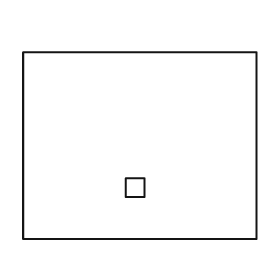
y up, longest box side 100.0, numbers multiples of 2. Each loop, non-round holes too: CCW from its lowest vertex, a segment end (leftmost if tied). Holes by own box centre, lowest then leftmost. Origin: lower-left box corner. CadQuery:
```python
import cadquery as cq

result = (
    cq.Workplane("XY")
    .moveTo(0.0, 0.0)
    .lineTo(100.0, 0.0)
    .lineTo(100.0, 80.0)
    .lineTo(0.0, 80.0)
    .close()
    .moveTo(44.0, 18.0)
    .lineTo(52.0, 18.0)
    .lineTo(52.0, 26.0)
    .lineTo(44.0, 26.0)
    .close()
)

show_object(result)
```